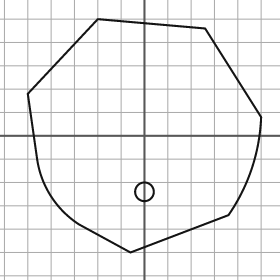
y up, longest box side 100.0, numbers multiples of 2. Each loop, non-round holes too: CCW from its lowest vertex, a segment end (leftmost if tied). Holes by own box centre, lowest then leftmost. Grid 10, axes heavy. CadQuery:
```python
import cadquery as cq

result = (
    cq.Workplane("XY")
    .moveTo(-6.0, -50.0)
    .lineTo(36.0, -34.0)
    .threePointArc((46.0, -14.0), (50.0, 8.0))
    .lineTo(26.0, 46.0)
    .lineTo(-20.0, 50.0)
    .lineTo(-50.0, 18.0)
    .lineTo(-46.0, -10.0)
    .threePointArc((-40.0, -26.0), (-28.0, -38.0))
    .close()
    .moveTo(0.0, -24.0)
    .circle(4.0)
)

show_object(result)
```